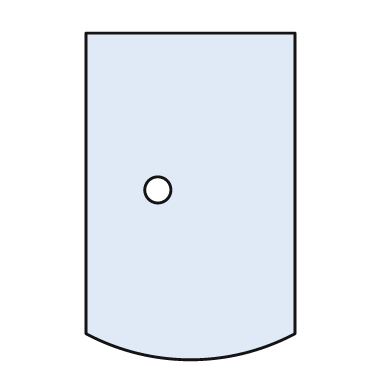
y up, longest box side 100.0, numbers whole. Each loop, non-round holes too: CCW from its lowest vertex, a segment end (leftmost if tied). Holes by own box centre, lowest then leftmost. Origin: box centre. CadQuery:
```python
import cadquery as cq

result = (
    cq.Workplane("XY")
    .moveTo(-32.0, -42.0)
    .threePointArc((0.0, -50.0), (32.0, -42.0))
    .lineTo(32.0, 50.0)
    .lineTo(-32.0, 50.0)
    .close()
    .moveTo(-10.0, 2.0)
    .circle(4.0)
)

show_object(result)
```